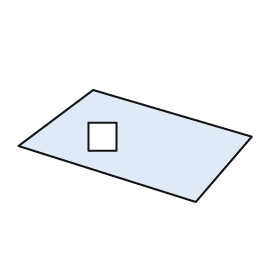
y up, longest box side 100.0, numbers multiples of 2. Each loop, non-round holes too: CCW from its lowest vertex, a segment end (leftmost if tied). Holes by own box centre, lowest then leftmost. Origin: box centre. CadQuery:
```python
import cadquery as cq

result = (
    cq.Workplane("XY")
    .moveTo(26.0, -24.0)
    .lineTo(50.0, 4.0)
    .lineTo(-18.0, 24.0)
    .lineTo(-50.0, 0.0)
    .close()
    .moveTo(-20.0, -2.0)
    .lineTo(-8.0, -2.0)
    .lineTo(-8.0, 10.0)
    .lineTo(-20.0, 10.0)
    .close()
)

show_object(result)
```